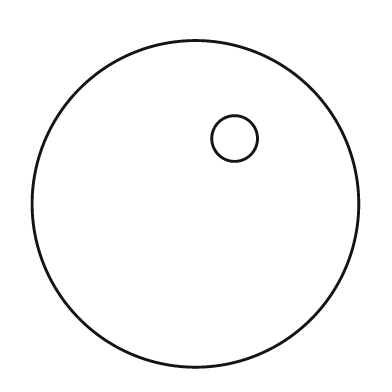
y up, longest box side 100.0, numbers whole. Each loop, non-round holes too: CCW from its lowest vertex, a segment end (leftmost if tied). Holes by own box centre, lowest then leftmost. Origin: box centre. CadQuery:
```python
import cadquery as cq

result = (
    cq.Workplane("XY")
    .moveTo(0.0, 0.0)
    .circle(50.0)
    .moveTo(12.0, 20.0)
    .circle(7.0)
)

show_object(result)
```